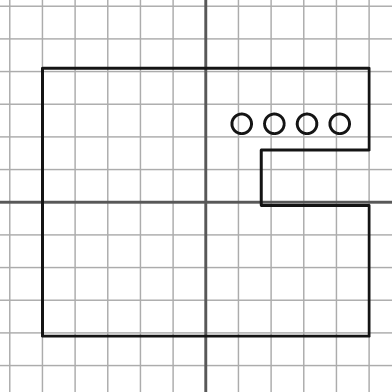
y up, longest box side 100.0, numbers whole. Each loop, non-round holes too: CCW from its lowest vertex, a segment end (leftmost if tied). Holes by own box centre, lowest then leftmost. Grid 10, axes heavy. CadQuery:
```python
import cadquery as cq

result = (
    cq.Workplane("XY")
    .moveTo(-50.0, -41.0)
    .lineTo(50.0, -41.0)
    .lineTo(50.0, -1.0)
    .lineTo(17.0, -1.0)
    .lineTo(17.0, 16.0)
    .lineTo(50.0, 16.0)
    .lineTo(50.0, 41.0)
    .lineTo(-50.0, 41.0)
    .close()
    .moveTo(11.0, 24.0)
    .circle(3.0)
    .moveTo(21.0, 24.0)
    .circle(3.0)
    .moveTo(31.0, 24.0)
    .circle(3.0)
    .moveTo(41.0, 24.0)
    .circle(3.0)
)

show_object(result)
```